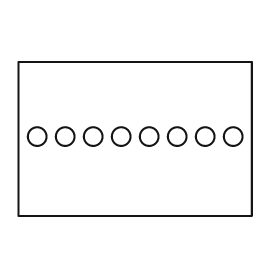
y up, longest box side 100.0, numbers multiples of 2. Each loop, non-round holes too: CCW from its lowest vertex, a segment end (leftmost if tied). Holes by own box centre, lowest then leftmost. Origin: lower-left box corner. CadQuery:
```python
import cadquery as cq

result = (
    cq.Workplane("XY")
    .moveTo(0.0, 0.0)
    .lineTo(100.0, 0.0)
    .lineTo(100.0, 66.0)
    .lineTo(0.0, 66.0)
    .close()
    .moveTo(8.0, 34.0)
    .circle(4.0)
    .moveTo(20.0, 34.0)
    .circle(4.0)
    .moveTo(32.0, 34.0)
    .circle(4.0)
    .moveTo(44.0, 34.0)
    .circle(4.0)
    .moveTo(56.0, 34.0)
    .circle(4.0)
    .moveTo(68.0, 34.0)
    .circle(4.0)
    .moveTo(80.0, 34.0)
    .circle(4.0)
    .moveTo(92.0, 34.0)
    .circle(4.0)
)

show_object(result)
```